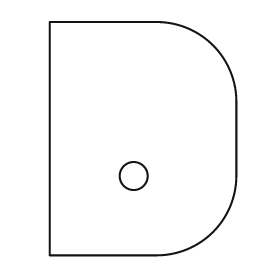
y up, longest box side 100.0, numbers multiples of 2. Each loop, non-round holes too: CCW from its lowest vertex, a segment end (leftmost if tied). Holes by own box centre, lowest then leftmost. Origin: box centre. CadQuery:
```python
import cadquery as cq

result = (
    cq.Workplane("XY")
    .moveTo(-40.0, -50.0)
    .lineTo(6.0, -50.0)
    .threePointArc((30.0, -40.0), (40.0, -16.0))
    .lineTo(40.0, 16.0)
    .threePointArc((30.0, 40.0), (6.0, 50.0))
    .lineTo(-40.0, 50.0)
    .close()
    .moveTo(-4.0, -16.0)
    .circle(6.0)
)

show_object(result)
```